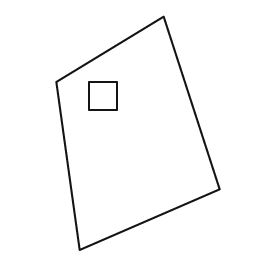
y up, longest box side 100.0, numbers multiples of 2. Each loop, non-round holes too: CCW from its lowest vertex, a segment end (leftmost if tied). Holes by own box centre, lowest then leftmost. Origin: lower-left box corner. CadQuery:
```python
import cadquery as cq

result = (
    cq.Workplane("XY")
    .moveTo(10.0, 0.0)
    .lineTo(70.0, 26.0)
    .lineTo(46.0, 100.0)
    .lineTo(0.0, 72.0)
    .close()
    .moveTo(14.0, 60.0)
    .lineTo(26.0, 60.0)
    .lineTo(26.0, 72.0)
    .lineTo(14.0, 72.0)
    .close()
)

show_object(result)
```